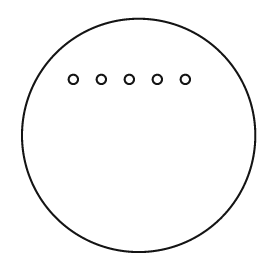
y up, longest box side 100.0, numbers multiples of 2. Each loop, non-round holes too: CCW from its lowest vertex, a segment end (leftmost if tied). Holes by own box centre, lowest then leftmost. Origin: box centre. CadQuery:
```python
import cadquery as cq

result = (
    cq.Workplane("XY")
    .moveTo(0.0, 0.0)
    .circle(50.0)
    .moveTo(-28.0, 24.0)
    .circle(2.0)
    .moveTo(-16.0, 24.0)
    .circle(2.0)
    .moveTo(-4.0, 24.0)
    .circle(2.0)
    .moveTo(8.0, 24.0)
    .circle(2.0)
    .moveTo(20.0, 24.0)
    .circle(2.0)
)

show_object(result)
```